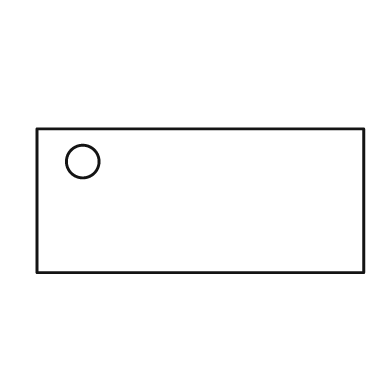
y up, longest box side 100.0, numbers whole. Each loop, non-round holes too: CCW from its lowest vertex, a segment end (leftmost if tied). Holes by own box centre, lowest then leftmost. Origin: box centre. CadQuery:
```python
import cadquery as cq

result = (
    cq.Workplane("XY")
    .moveTo(-50.0, -22.0)
    .lineTo(50.0, -22.0)
    .lineTo(50.0, 22.0)
    .lineTo(-50.0, 22.0)
    .close()
    .moveTo(-36.0, 12.0)
    .circle(5.0)
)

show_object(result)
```